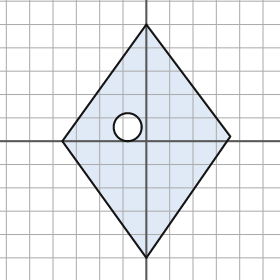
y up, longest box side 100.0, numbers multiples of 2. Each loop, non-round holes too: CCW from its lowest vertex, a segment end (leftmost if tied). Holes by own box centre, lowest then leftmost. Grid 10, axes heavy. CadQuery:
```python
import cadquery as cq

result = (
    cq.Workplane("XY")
    .moveTo(0.0, -50.0)
    .lineTo(36.0, 2.0)
    .lineTo(0.0, 50.0)
    .lineTo(-36.0, 0.0)
    .close()
    .moveTo(-8.0, 6.0)
    .circle(6.0)
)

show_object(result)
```